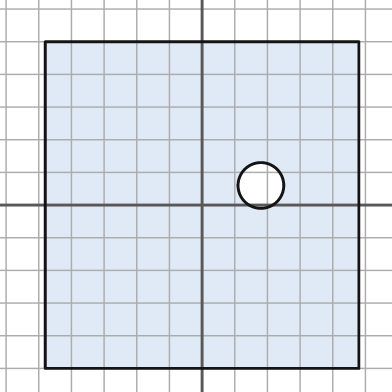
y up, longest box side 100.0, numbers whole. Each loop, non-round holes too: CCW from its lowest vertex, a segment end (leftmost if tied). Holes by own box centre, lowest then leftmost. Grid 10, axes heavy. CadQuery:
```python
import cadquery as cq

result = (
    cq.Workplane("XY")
    .moveTo(-48.0, -50.0)
    .lineTo(48.0, -50.0)
    .lineTo(48.0, 50.0)
    .lineTo(-48.0, 50.0)
    .close()
    .moveTo(18.0, 6.0)
    .circle(7.0)
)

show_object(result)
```